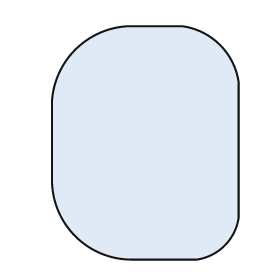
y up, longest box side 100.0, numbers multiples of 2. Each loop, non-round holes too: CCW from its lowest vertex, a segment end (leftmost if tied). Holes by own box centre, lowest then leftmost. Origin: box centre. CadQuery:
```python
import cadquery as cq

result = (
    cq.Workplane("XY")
    .moveTo(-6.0, -50.0)
    .lineTo(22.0, -50.0)
    .threePointArc((34.0, -44.0), (40.0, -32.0))
    .lineTo(40.0, 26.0)
    .threePointArc((32.0, 42.0), (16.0, 50.0))
    .lineTo(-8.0, 50.0)
    .threePointArc((-30.0, 40.0), (-40.0, 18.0))
    .lineTo(-40.0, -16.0)
    .threePointArc((-30.0, -40.0), (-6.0, -50.0))
    .close()
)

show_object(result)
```